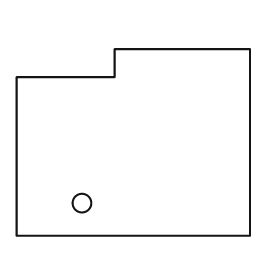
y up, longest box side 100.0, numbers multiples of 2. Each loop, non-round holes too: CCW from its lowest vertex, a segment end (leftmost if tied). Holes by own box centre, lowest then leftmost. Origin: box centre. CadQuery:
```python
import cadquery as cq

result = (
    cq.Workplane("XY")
    .moveTo(-50.0, -40.0)
    .lineTo(50.0, -40.0)
    .lineTo(50.0, 40.0)
    .lineTo(-8.0, 40.0)
    .lineTo(-8.0, 28.0)
    .lineTo(-50.0, 28.0)
    .close()
    .moveTo(-22.0, -26.0)
    .circle(4.0)
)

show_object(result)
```